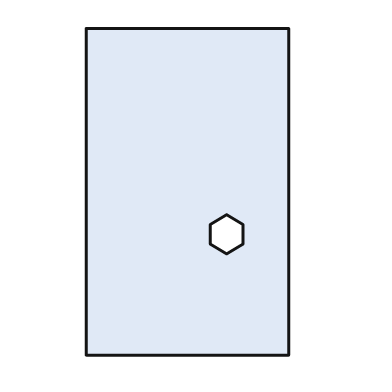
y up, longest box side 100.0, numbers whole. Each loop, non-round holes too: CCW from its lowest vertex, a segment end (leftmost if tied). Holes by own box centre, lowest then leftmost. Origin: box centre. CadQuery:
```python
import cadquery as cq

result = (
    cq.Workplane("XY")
    .moveTo(-31.0, -50.0)
    .lineTo(31.0, -50.0)
    .lineTo(31.0, 50.0)
    .lineTo(-31.0, 50.0)
    .close()
    .moveTo(12.0, -19.0)
    .lineTo(17.0, -16.0)
    .lineTo(17.0, -10.0)
    .lineTo(12.0, -7.0)
    .lineTo(7.0, -10.0)
    .lineTo(7.0, -16.0)
    .close()
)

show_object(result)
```